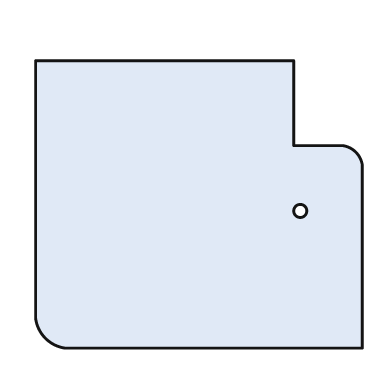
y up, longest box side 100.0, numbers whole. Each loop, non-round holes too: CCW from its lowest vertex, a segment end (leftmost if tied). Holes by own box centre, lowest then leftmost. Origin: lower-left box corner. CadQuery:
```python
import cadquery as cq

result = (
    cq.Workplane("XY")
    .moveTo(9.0, 0.0)
    .lineTo(100.0, 0.0)
    .lineTo(100.0, 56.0)
    .threePointArc((98.0, 60.0), (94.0, 62.0))
    .lineTo(79.0, 62.0)
    .lineTo(79.0, 88.0)
    .lineTo(0.0, 88.0)
    .lineTo(0.0, 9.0)
    .threePointArc((3.0, 3.0), (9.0, 0.0))
    .close()
    .moveTo(81.0, 42.0)
    .circle(2.0)
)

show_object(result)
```